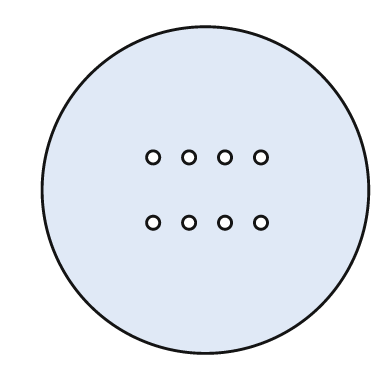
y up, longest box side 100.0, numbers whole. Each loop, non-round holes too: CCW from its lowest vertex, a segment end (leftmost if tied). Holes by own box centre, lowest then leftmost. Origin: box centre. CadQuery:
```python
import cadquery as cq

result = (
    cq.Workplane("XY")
    .moveTo(0.0, 0.0)
    .circle(50.0)
    .moveTo(-16.0, -10.0)
    .circle(2.0)
    .moveTo(-5.0, -10.0)
    .circle(2.0)
    .moveTo(6.0, -10.0)
    .circle(2.0)
    .moveTo(17.0, -10.0)
    .circle(2.0)
    .moveTo(-16.0, 10.0)
    .circle(2.0)
    .moveTo(-5.0, 10.0)
    .circle(2.0)
    .moveTo(6.0, 10.0)
    .circle(2.0)
    .moveTo(17.0, 10.0)
    .circle(2.0)
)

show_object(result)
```